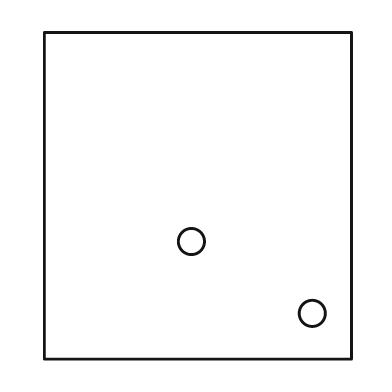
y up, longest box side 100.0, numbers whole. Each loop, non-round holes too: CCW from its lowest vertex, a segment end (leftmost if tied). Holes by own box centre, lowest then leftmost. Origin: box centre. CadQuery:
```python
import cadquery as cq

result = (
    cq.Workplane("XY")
    .moveTo(-47.0, -50.0)
    .lineTo(47.0, -50.0)
    .lineTo(47.0, 50.0)
    .lineTo(-47.0, 50.0)
    .close()
    .moveTo(35.0, -36.0)
    .circle(4.0)
    .moveTo(-2.0, -14.0)
    .circle(4.0)
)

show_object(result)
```